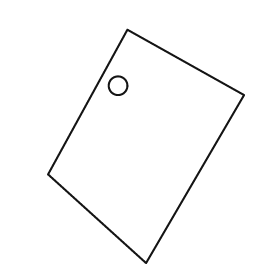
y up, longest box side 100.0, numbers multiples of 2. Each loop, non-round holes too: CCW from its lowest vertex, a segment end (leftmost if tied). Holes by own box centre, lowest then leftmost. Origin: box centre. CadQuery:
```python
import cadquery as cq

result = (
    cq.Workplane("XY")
    .moveTo(0.0, -50.0)
    .lineTo(42.0, 22.0)
    .lineTo(-8.0, 50.0)
    .lineTo(-42.0, -12.0)
    .close()
    .moveTo(-12.0, 26.0)
    .circle(4.0)
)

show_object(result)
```